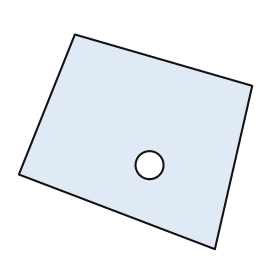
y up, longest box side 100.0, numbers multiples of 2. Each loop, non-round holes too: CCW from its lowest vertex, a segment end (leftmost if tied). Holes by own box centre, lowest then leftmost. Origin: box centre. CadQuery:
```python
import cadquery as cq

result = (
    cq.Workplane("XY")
    .moveTo(34.0, -46.0)
    .lineTo(50.0, 24.0)
    .lineTo(-26.0, 46.0)
    .lineTo(-50.0, -14.0)
    .close()
    .moveTo(6.0, -10.0)
    .circle(6.0)
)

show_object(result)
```